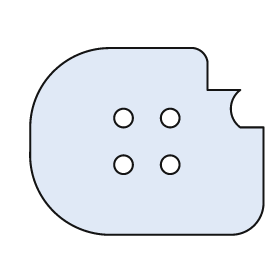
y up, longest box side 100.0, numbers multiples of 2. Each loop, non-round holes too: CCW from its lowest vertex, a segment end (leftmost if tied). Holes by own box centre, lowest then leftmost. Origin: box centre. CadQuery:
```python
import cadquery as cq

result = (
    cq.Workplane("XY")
    .moveTo(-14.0, -40.0)
    .lineTo(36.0, -40.0)
    .threePointArc((46.0, -36.0), (50.0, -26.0))
    .lineTo(50.0, 6.0)
    .lineTo(40.0, 6.0)
    .threePointArc((36.0, 14.0), (40.0, 22.0))
    .lineTo(26.0, 22.0)
    .lineTo(26.0, 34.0)
    .threePointArc((24.0, 38.0), (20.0, 40.0))
    .lineTo(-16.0, 40.0)
    .threePointArc((-40.0, 30.0), (-50.0, 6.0))
    .lineTo(-50.0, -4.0)
    .threePointArc((-40.0, -30.0), (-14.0, -40.0))
    .close()
    .moveTo(-10.0, -10.0)
    .circle(4.0)
    .moveTo(10.0, -10.0)
    .circle(4.0)
    .moveTo(-10.0, 10.0)
    .circle(4.0)
    .moveTo(10.0, 10.0)
    .circle(4.0)
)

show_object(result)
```